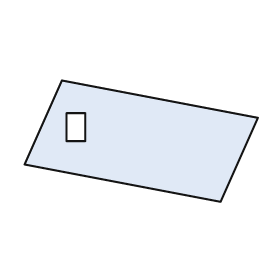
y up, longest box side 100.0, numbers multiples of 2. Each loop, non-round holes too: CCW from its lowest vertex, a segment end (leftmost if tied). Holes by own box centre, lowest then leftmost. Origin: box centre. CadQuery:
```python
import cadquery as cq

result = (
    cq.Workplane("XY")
    .moveTo(34.0, -26.0)
    .lineTo(50.0, 10.0)
    .lineTo(-34.0, 26.0)
    .lineTo(-50.0, -10.0)
    .close()
    .moveTo(-32.0, 0.0)
    .lineTo(-24.0, 0.0)
    .lineTo(-24.0, 12.0)
    .lineTo(-32.0, 12.0)
    .close()
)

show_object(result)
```